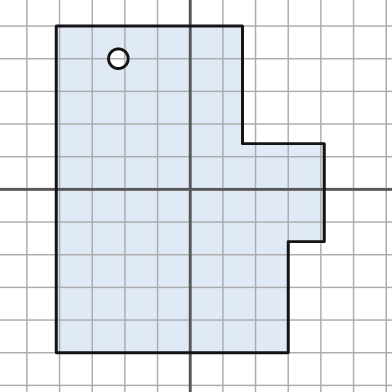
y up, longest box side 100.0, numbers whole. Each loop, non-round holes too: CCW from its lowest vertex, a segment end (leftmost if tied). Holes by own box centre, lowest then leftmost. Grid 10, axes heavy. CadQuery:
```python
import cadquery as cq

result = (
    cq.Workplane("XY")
    .moveTo(-41.0, -50.0)
    .lineTo(30.0, -50.0)
    .lineTo(30.0, -16.0)
    .lineTo(41.0, -16.0)
    .lineTo(41.0, 14.0)
    .lineTo(16.0, 14.0)
    .lineTo(16.0, 50.0)
    .lineTo(-41.0, 50.0)
    .close()
    .moveTo(-22.0, 40.0)
    .circle(3.0)
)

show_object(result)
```